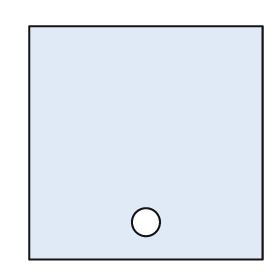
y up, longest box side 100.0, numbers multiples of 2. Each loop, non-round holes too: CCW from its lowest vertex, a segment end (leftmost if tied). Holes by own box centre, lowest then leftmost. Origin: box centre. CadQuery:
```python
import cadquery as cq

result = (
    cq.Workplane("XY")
    .moveTo(-50.0, -50.0)
    .lineTo(50.0, -50.0)
    .lineTo(50.0, 50.0)
    .lineTo(-50.0, 50.0)
    .close()
    .moveTo(0.0, -34.0)
    .circle(6.0)
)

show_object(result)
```